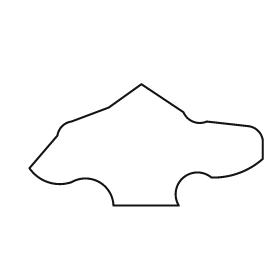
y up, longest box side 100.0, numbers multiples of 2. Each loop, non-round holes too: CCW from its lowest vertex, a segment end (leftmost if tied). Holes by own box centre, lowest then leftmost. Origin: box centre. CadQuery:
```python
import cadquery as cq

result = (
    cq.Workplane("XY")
    .moveTo(-14.0, -26.0)
    .lineTo(14.0, -26.0)
    .threePointArc((16.0, -14.0), (28.0, -14.0))
    .threePointArc((40.0, -12.0), (50.0, -6.0))
    .lineTo(50.0, 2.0)
    .threePointArc((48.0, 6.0), (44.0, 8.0))
    .lineTo(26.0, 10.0)
    .threePointArc((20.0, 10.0), (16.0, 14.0))
    .lineTo(-2.0, 26.0)
    .lineTo(-16.0, 16.0)
    .lineTo(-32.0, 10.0)
    .threePointArc((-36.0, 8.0), (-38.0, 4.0))
    .lineTo(-50.0, -10.0)
    .threePointArc((-42.0, -16.0), (-32.0, -16.0))
    .threePointArc((-20.0, -16.0), (-14.0, -26.0))
    .close()
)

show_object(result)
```